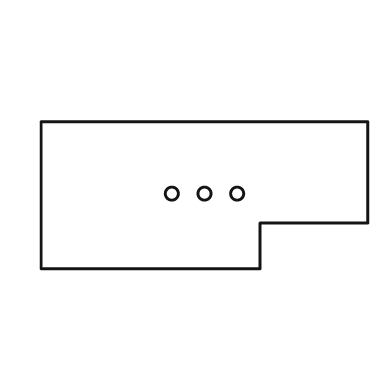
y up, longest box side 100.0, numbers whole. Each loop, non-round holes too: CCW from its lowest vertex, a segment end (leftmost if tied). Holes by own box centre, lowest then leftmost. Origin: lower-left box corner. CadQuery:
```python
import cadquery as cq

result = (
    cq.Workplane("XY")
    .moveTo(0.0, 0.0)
    .lineTo(67.0, 0.0)
    .lineTo(67.0, 14.0)
    .lineTo(100.0, 14.0)
    .lineTo(100.0, 45.0)
    .lineTo(0.0, 45.0)
    .close()
    .moveTo(40.0, 23.0)
    .circle(2.0)
    .moveTo(50.0, 23.0)
    .circle(2.0)
    .moveTo(60.0, 23.0)
    .circle(2.0)
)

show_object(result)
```